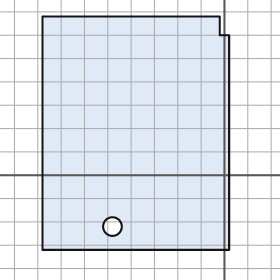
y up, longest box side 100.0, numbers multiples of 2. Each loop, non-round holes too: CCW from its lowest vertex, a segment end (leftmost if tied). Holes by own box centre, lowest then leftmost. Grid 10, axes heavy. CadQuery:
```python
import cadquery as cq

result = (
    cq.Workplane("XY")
    .moveTo(-78.0, -32.0)
    .lineTo(2.0, -32.0)
    .lineTo(2.0, 60.0)
    .lineTo(-2.0, 60.0)
    .lineTo(-2.0, 68.0)
    .lineTo(-78.0, 68.0)
    .close()
    .moveTo(-48.0, -22.0)
    .circle(4.0)
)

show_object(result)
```